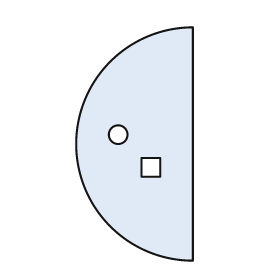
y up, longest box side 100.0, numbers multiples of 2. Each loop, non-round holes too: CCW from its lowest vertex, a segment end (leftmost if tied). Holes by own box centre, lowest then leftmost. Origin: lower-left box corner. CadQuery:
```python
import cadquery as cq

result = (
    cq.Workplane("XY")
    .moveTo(50.0, 0.0)
    .lineTo(50.0, 100.0)
    .threePointArc((0.0, 50.0), (50.0, 0.0))
    .close()
    .moveTo(28.0, 36.0)
    .lineTo(36.0, 36.0)
    .lineTo(36.0, 44.0)
    .lineTo(28.0, 44.0)
    .close()
    .moveTo(18.0, 54.0)
    .circle(4.0)
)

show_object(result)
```